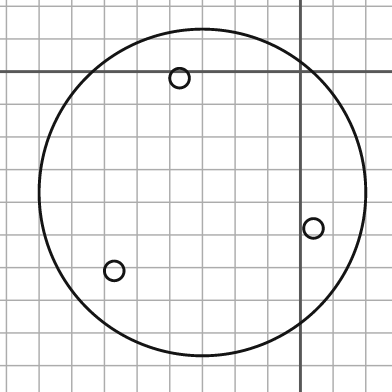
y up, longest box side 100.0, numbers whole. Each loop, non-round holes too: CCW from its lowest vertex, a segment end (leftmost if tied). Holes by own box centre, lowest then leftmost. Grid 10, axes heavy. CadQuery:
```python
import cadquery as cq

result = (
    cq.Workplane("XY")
    .moveTo(-30.0, -37.0)
    .circle(50.0)
    .moveTo(-57.0, -61.0)
    .circle(3.0)
    .moveTo(4.0, -48.0)
    .circle(3.0)
    .moveTo(-37.0, -2.0)
    .circle(3.0)
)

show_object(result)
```